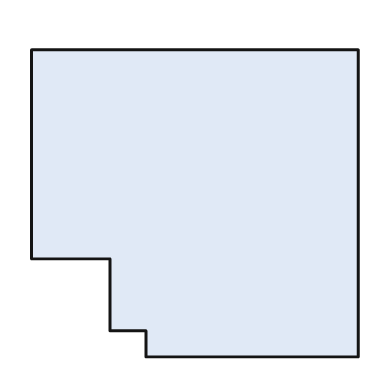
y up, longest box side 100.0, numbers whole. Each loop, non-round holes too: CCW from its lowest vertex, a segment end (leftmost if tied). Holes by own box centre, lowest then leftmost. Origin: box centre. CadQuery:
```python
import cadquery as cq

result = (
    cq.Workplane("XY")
    .moveTo(-15.0, -47.0)
    .lineTo(50.0, -47.0)
    .lineTo(50.0, 47.0)
    .lineTo(-50.0, 47.0)
    .lineTo(-50.0, -17.0)
    .lineTo(-26.0, -17.0)
    .lineTo(-26.0, -39.0)
    .lineTo(-15.0, -39.0)
    .close()
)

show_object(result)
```